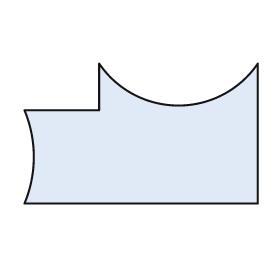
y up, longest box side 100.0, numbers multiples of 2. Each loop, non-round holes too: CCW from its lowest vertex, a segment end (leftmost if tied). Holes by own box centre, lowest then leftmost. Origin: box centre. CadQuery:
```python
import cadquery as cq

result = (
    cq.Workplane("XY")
    .moveTo(-50.0, -30.0)
    .lineTo(50.0, -30.0)
    .lineTo(50.0, 30.0)
    .threePointArc((16.0, 12.0), (-18.0, 30.0))
    .lineTo(-18.0, 10.0)
    .lineTo(-50.0, 10.0)
    .threePointArc((-46.0, -10.0), (-50.0, -30.0))
    .close()
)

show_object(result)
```